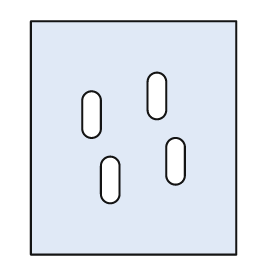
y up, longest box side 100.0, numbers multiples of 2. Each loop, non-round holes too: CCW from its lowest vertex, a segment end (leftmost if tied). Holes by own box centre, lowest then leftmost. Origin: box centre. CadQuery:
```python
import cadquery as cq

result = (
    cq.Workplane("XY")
    .moveTo(-44.0, -50.0)
    .lineTo(44.0, -50.0)
    .lineTo(44.0, 50.0)
    .lineTo(-44.0, 50.0)
    .close()
    .moveTo(-14.0, -24.0)
    .threePointArc((-10.0, -28.0), (-6.0, -24.0))
    .lineTo(-6.0, -12.0)
    .threePointArc((-10.0, -8.0), (-14.0, -12.0))
    .close()
    .moveTo(14.0, -16.0)
    .threePointArc((18.0, -20.0), (22.0, -16.0))
    .lineTo(22.0, -4.0)
    .threePointArc((18.0, 0.0), (14.0, -4.0))
    .close()
    .moveTo(-22.0, 4.0)
    .threePointArc((-18.0, 0.0), (-14.0, 4.0))
    .lineTo(-14.0, 16.0)
    .threePointArc((-18.0, 20.0), (-22.0, 16.0))
    .close()
    .moveTo(6.0, 12.0)
    .threePointArc((10.0, 8.0), (14.0, 12.0))
    .lineTo(14.0, 24.0)
    .threePointArc((10.0, 28.0), (6.0, 24.0))
    .close()
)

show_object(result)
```